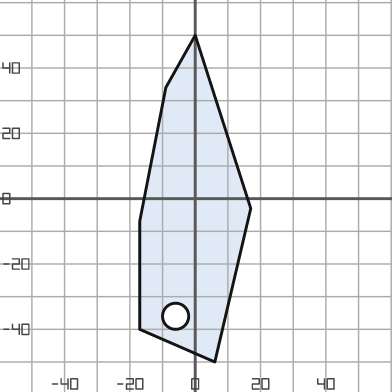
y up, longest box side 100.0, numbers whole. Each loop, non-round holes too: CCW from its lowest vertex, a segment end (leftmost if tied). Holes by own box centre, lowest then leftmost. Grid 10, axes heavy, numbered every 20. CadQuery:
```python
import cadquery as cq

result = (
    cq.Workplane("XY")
    .moveTo(6.0, -50.0)
    .lineTo(17.0, -3.0)
    .lineTo(0.0, 50.0)
    .lineTo(-9.0, 34.0)
    .lineTo(-17.0, -7.0)
    .lineTo(-17.0, -40.0)
    .close()
    .moveTo(-6.0, -36.0)
    .circle(4.0)
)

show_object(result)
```